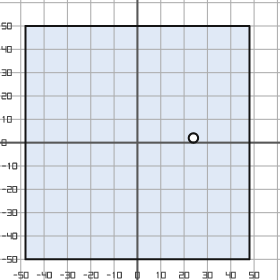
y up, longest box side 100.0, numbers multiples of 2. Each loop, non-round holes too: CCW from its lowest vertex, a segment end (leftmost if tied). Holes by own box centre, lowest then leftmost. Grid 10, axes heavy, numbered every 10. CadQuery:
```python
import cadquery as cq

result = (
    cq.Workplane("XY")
    .moveTo(-48.0, -50.0)
    .lineTo(48.0, -50.0)
    .lineTo(48.0, 50.0)
    .lineTo(-48.0, 50.0)
    .close()
    .moveTo(24.0, 2.0)
    .circle(2.0)
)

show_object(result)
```